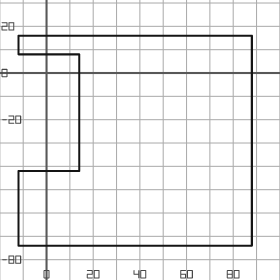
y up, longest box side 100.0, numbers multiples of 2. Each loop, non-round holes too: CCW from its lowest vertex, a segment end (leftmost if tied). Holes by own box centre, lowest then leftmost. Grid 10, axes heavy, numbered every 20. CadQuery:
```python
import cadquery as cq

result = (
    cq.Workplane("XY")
    .moveTo(-12.0, -74.0)
    .lineTo(88.0, -74.0)
    .lineTo(88.0, 16.0)
    .lineTo(-12.0, 16.0)
    .lineTo(-12.0, 8.0)
    .lineTo(14.0, 8.0)
    .lineTo(14.0, -42.0)
    .lineTo(-12.0, -42.0)
    .close()
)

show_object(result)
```